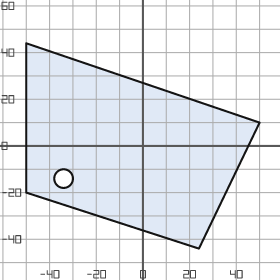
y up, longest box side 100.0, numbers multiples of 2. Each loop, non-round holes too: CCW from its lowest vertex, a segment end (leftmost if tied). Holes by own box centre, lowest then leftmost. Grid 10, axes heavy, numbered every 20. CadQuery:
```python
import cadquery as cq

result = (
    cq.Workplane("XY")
    .moveTo(24.0, -44.0)
    .lineTo(50.0, 10.0)
    .lineTo(-50.0, 44.0)
    .lineTo(-50.0, -20.0)
    .close()
    .moveTo(-34.0, -14.0)
    .circle(4.0)
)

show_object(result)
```